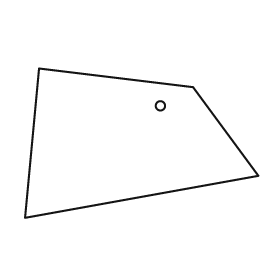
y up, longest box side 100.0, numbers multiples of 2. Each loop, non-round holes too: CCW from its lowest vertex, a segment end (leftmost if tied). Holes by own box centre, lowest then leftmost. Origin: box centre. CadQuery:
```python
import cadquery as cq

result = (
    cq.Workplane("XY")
    .moveTo(-50.0, -32.0)
    .lineTo(50.0, -14.0)
    .lineTo(22.0, 24.0)
    .lineTo(-44.0, 32.0)
    .close()
    .moveTo(8.0, 16.0)
    .circle(2.0)
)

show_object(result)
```